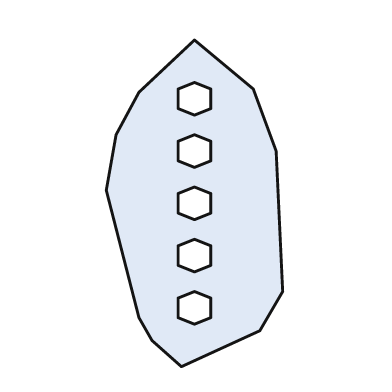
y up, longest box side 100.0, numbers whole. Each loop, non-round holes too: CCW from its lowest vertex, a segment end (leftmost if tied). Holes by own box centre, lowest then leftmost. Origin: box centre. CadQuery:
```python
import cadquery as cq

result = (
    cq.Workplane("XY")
    .moveTo(-4.0, -50.0)
    .lineTo(20.0, -39.0)
    .lineTo(27.0, -27.0)
    .lineTo(25.0, 16.0)
    .lineTo(18.0, 35.0)
    .lineTo(0.0, 50.0)
    .lineTo(-17.0, 34.0)
    .lineTo(-24.0, 21.0)
    .lineTo(-27.0, 4.0)
    .lineTo(-17.0, -35.0)
    .lineTo(-13.0, -42.0)
    .close()
    .moveTo(0.0, -37.0)
    .lineTo(5.0, -35.0)
    .lineTo(5.0, -29.0)
    .lineTo(0.0, -27.0)
    .lineTo(-5.0, -29.0)
    .lineTo(-5.0, -35.0)
    .close()
    .moveTo(0.0, -21.0)
    .lineTo(5.0, -19.0)
    .lineTo(5.0, -13.0)
    .lineTo(0.0, -11.0)
    .lineTo(-5.0, -13.0)
    .lineTo(-5.0, -19.0)
    .close()
    .moveTo(0.0, -5.0)
    .lineTo(5.0, -3.0)
    .lineTo(5.0, 3.0)
    .lineTo(0.0, 5.0)
    .lineTo(-5.0, 3.0)
    .lineTo(-5.0, -3.0)
    .close()
    .moveTo(0.0, 11.0)
    .lineTo(5.0, 13.0)
    .lineTo(5.0, 19.0)
    .lineTo(0.0, 21.0)
    .lineTo(-5.0, 19.0)
    .lineTo(-5.0, 13.0)
    .close()
    .moveTo(0.0, 27.0)
    .lineTo(5.0, 29.0)
    .lineTo(5.0, 35.0)
    .lineTo(0.0, 37.0)
    .lineTo(-5.0, 35.0)
    .lineTo(-5.0, 29.0)
    .close()
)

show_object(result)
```